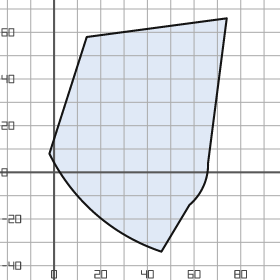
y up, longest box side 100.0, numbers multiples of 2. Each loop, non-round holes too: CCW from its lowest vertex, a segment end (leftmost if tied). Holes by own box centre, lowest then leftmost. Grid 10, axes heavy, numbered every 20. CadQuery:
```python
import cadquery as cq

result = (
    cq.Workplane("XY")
    .moveTo(46.0, -34.0)
    .lineTo(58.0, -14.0)
    .threePointArc((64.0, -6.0), (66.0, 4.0))
    .lineTo(74.0, 66.0)
    .lineTo(14.0, 58.0)
    .lineTo(-2.0, 8.0)
    .threePointArc((18.0, -18.0), (46.0, -34.0))
    .close()
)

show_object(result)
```